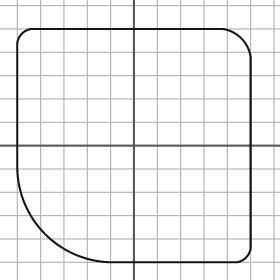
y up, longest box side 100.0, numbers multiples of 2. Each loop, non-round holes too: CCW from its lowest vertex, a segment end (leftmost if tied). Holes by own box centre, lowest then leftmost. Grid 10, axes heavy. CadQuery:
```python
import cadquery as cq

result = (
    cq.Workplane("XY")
    .moveTo(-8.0, -50.0)
    .lineTo(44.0, -50.0)
    .threePointArc((48.0, -48.0), (50.0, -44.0))
    .lineTo(50.0, 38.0)
    .threePointArc((46.0, 46.0), (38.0, 50.0))
    .lineTo(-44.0, 50.0)
    .threePointArc((-48.0, 48.0), (-50.0, 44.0))
    .lineTo(-50.0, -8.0)
    .threePointArc((-38.0, -38.0), (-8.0, -50.0))
    .close()
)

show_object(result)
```